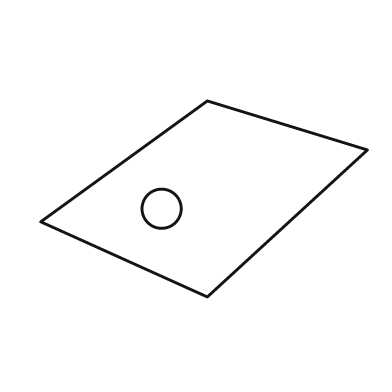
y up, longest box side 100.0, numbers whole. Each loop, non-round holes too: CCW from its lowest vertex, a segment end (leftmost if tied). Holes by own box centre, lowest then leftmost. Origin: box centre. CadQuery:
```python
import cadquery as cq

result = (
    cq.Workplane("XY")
    .moveTo(1.0, -30.0)
    .lineTo(50.0, 15.0)
    .lineTo(1.0, 30.0)
    .lineTo(-50.0, -7.0)
    .close()
    .moveTo(-13.0, -3.0)
    .circle(6.0)
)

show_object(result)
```